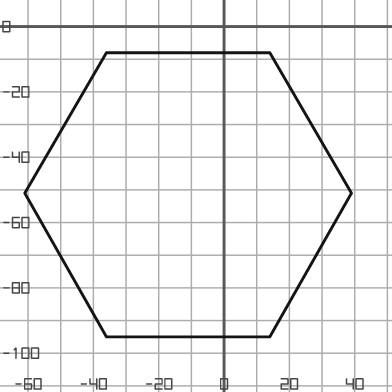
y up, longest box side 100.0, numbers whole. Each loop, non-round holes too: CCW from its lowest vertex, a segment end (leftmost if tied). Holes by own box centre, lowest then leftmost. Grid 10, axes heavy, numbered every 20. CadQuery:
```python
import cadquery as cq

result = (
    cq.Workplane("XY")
    .moveTo(-36.0, -95.0)
    .lineTo(14.0, -95.0)
    .lineTo(39.0, -51.0)
    .lineTo(14.0, -8.0)
    .lineTo(-36.0, -8.0)
    .lineTo(-61.0, -51.0)
    .close()
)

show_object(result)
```